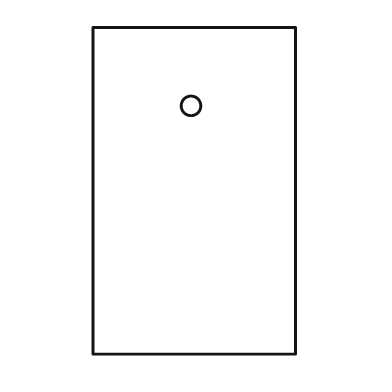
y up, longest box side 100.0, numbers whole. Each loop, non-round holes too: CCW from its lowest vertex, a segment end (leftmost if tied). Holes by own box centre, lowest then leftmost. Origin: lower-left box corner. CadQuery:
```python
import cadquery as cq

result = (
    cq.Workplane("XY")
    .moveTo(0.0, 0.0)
    .lineTo(62.0, 0.0)
    .lineTo(62.0, 100.0)
    .lineTo(0.0, 100.0)
    .close()
    .moveTo(30.0, 76.0)
    .circle(3.0)
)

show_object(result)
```